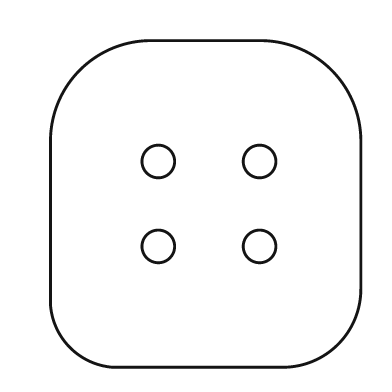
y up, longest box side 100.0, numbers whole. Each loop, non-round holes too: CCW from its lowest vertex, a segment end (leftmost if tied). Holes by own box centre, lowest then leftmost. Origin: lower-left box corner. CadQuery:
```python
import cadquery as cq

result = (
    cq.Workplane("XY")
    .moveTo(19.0, 0.0)
    .lineTo(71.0, 0.0)
    .threePointArc((88.0, 7.0), (95.0, 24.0))
    .lineTo(95.0, 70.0)
    .threePointArc((86.0, 91.0), (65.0, 100.0))
    .lineTo(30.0, 100.0)
    .threePointArc((9.0, 91.0), (0.0, 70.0))
    .lineTo(0.0, 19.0)
    .threePointArc((6.0, 6.0), (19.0, 0.0))
    .close()
    .moveTo(33.0, 37.0)
    .circle(5.0)
    .moveTo(64.0, 37.0)
    .circle(5.0)
    .moveTo(33.0, 63.0)
    .circle(5.0)
    .moveTo(64.0, 63.0)
    .circle(5.0)
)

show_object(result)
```